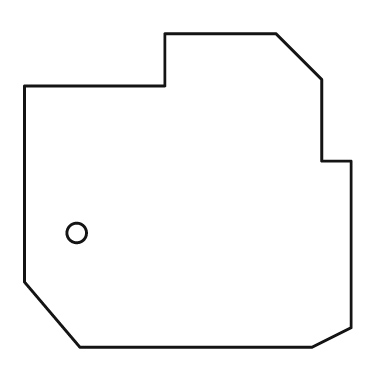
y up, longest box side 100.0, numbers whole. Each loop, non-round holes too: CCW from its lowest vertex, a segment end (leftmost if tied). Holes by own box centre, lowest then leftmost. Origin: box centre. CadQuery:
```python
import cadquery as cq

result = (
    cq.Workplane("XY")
    .moveTo(-33.0, -48.0)
    .lineTo(38.0, -48.0)
    .lineTo(50.0, -42.0)
    .lineTo(50.0, 9.0)
    .lineTo(41.0, 9.0)
    .lineTo(41.0, 34.0)
    .lineTo(27.0, 48.0)
    .lineTo(-7.0, 48.0)
    .lineTo(-7.0, 32.0)
    .lineTo(-50.0, 32.0)
    .lineTo(-50.0, -28.0)
    .close()
    .moveTo(-34.0, -13.0)
    .circle(3.0)
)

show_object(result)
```